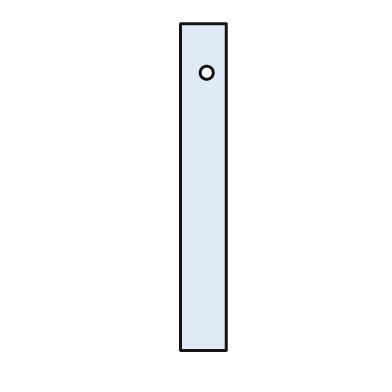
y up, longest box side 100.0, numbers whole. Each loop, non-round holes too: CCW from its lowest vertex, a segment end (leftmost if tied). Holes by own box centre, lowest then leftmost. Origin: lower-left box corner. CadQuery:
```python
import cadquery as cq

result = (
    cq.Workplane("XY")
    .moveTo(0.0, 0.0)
    .lineTo(14.0, 0.0)
    .lineTo(14.0, 100.0)
    .lineTo(0.0, 100.0)
    .close()
    .moveTo(8.0, 85.0)
    .circle(2.0)
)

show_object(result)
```